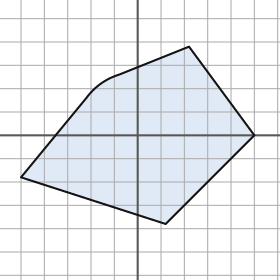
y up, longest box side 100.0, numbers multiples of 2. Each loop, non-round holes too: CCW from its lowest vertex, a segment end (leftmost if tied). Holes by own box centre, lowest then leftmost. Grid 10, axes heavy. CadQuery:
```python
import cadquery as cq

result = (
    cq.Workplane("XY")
    .moveTo(12.0, -38.0)
    .lineTo(50.0, 0.0)
    .lineTo(22.0, 38.0)
    .lineTo(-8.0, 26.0)
    .threePointArc((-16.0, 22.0), (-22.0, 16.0))
    .lineTo(-50.0, -18.0)
    .close()
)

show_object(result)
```